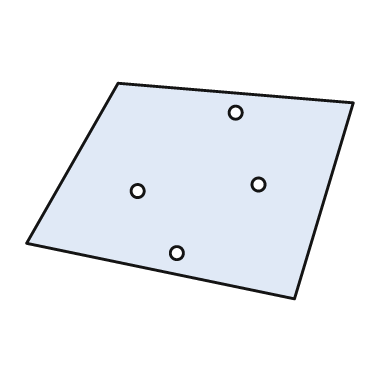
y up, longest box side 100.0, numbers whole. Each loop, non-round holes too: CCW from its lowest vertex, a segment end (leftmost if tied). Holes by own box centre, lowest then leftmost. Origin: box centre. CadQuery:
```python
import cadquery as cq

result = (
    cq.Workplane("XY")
    .moveTo(32.0, -33.0)
    .lineTo(50.0, 27.0)
    .lineTo(-22.0, 33.0)
    .lineTo(-50.0, -16.0)
    .close()
    .moveTo(-4.0, -19.0)
    .circle(2.0)
    .moveTo(-16.0, 0.0)
    .circle(2.0)
    .moveTo(21.0, 2.0)
    .circle(2.0)
    .moveTo(14.0, 24.0)
    .circle(2.0)
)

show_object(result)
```